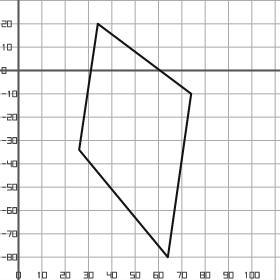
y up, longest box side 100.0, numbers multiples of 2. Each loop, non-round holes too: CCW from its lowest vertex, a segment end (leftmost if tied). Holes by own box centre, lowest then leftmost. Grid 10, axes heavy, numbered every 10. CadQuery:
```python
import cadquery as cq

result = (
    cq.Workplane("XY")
    .moveTo(64.0, -80.0)
    .lineTo(74.0, -10.0)
    .lineTo(34.0, 20.0)
    .lineTo(26.0, -34.0)
    .close()
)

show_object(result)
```